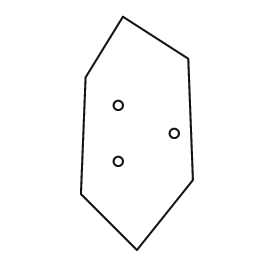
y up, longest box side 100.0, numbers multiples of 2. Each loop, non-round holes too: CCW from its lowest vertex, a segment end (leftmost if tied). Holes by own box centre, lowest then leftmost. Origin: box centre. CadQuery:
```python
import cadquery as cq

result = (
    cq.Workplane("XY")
    .moveTo(0.0, -50.0)
    .lineTo(24.0, -20.0)
    .lineTo(22.0, 32.0)
    .lineTo(-6.0, 50.0)
    .lineTo(-22.0, 24.0)
    .lineTo(-24.0, -26.0)
    .close()
    .moveTo(-8.0, -12.0)
    .circle(2.0)
    .moveTo(16.0, 0.0)
    .circle(2.0)
    .moveTo(-8.0, 12.0)
    .circle(2.0)
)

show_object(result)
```